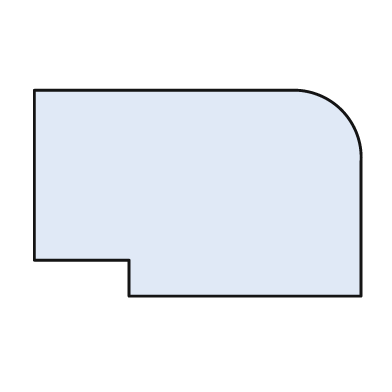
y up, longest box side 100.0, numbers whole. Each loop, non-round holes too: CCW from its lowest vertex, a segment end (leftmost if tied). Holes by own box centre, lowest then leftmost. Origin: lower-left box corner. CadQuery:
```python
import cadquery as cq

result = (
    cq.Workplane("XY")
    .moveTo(29.0, 0.0)
    .lineTo(100.0, 0.0)
    .lineTo(100.0, 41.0)
    .threePointArc((94.0, 57.0), (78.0, 63.0))
    .lineTo(0.0, 63.0)
    .lineTo(0.0, 11.0)
    .lineTo(29.0, 11.0)
    .close()
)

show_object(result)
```